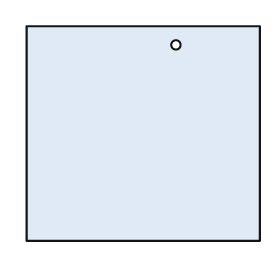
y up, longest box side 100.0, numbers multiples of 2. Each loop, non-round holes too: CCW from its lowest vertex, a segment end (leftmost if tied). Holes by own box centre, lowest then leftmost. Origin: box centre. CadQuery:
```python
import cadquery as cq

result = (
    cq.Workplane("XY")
    .moveTo(-50.0, -46.0)
    .lineTo(50.0, -46.0)
    .lineTo(50.0, 46.0)
    .lineTo(-50.0, 46.0)
    .close()
    .moveTo(14.0, 38.0)
    .circle(2.0)
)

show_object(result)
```